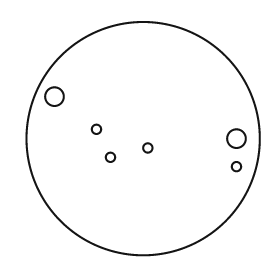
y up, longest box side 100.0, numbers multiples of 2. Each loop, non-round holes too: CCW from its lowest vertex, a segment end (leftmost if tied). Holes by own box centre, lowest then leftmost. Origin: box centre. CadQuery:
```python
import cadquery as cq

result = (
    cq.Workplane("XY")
    .moveTo(0.0, 0.0)
    .circle(50.0)
    .moveTo(40.0, -12.0)
    .circle(2.0)
    .moveTo(-14.0, -8.0)
    .circle(2.0)
    .moveTo(2.0, -4.0)
    .circle(2.0)
    .moveTo(40.0, 0.0)
    .circle(4.0)
    .moveTo(-20.0, 4.0)
    .circle(2.0)
    .moveTo(-38.0, 18.0)
    .circle(4.0)
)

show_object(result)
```